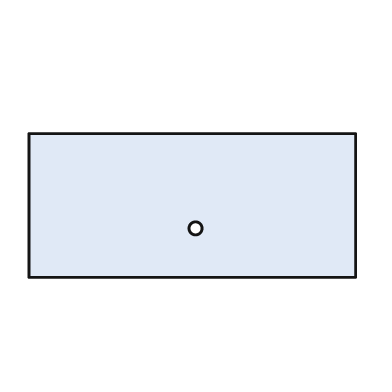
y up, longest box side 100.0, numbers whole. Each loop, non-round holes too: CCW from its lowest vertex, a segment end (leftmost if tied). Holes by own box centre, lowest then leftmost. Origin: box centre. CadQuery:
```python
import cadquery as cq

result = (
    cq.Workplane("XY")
    .moveTo(-50.0, -22.0)
    .lineTo(50.0, -22.0)
    .lineTo(50.0, 22.0)
    .lineTo(-50.0, 22.0)
    .close()
    .moveTo(1.0, -7.0)
    .circle(2.0)
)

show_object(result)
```